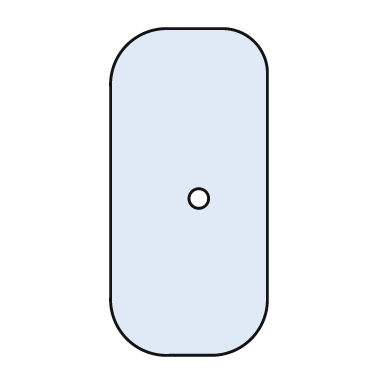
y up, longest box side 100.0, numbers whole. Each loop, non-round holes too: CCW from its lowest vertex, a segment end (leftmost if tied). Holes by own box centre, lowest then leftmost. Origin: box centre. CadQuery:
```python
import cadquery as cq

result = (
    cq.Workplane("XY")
    .moveTo(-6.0, -50.0)
    .lineTo(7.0, -50.0)
    .threePointArc((19.0, -45.0), (24.0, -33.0))
    .lineTo(24.0, 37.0)
    .threePointArc((20.0, 46.0), (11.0, 50.0))
    .lineTo(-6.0, 50.0)
    .threePointArc((-19.0, 45.0), (-24.0, 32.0))
    .lineTo(-24.0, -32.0)
    .threePointArc((-19.0, -45.0), (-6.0, -50.0))
    .close()
    .moveTo(3.0, -2.0)
    .circle(3.0)
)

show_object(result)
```